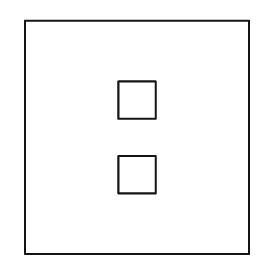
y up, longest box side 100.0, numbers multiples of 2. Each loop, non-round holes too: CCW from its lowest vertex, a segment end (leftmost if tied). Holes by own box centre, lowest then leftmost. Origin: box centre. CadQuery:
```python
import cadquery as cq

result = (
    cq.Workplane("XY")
    .moveTo(-48.0, -50.0)
    .lineTo(48.0, -50.0)
    .lineTo(48.0, 50.0)
    .lineTo(-48.0, 50.0)
    .close()
    .moveTo(-8.0, -24.0)
    .lineTo(8.0, -24.0)
    .lineTo(8.0, -8.0)
    .lineTo(-8.0, -8.0)
    .close()
    .moveTo(-8.0, 8.0)
    .lineTo(8.0, 8.0)
    .lineTo(8.0, 24.0)
    .lineTo(-8.0, 24.0)
    .close()
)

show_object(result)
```